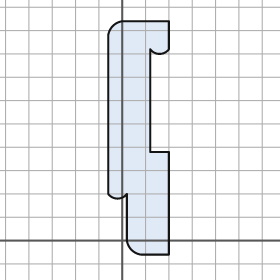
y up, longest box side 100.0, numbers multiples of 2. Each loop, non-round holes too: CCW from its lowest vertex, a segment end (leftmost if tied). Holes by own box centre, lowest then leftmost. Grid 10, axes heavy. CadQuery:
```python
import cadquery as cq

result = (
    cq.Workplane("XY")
    .moveTo(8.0, -6.0)
    .lineTo(20.0, -6.0)
    .lineTo(20.0, 38.0)
    .lineTo(12.0, 38.0)
    .lineTo(12.0, 82.0)
    .threePointArc((16.0, 80.0), (20.0, 82.0))
    .lineTo(20.0, 94.0)
    .lineTo(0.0, 94.0)
    .threePointArc((-4.0, 92.0), (-6.0, 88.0))
    .lineTo(-6.0, 20.0)
    .threePointArc((-2.0, 18.0), (2.0, 20.0))
    .lineTo(2.0, 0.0)
    .threePointArc((4.0, -4.0), (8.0, -6.0))
    .close()
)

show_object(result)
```